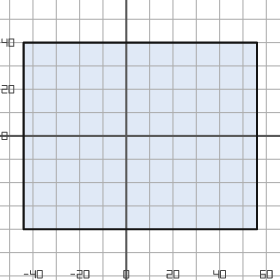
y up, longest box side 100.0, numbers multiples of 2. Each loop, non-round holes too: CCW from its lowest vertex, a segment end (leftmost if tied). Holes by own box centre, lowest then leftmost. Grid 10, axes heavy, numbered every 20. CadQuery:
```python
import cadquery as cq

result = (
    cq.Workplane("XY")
    .moveTo(-44.0, -40.0)
    .lineTo(56.0, -40.0)
    .lineTo(56.0, 40.0)
    .lineTo(-44.0, 40.0)
    .close()
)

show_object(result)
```